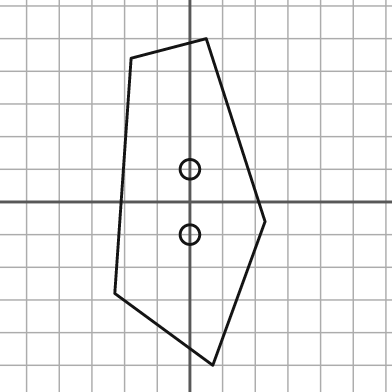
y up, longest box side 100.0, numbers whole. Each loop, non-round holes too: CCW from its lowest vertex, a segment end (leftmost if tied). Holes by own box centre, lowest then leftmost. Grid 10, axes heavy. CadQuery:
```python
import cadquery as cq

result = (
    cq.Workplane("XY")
    .moveTo(7.0, -50.0)
    .lineTo(23.0, -6.0)
    .lineTo(5.0, 50.0)
    .lineTo(-18.0, 44.0)
    .lineTo(-23.0, -28.0)
    .close()
    .moveTo(0.0, -10.0)
    .circle(3.0)
    .moveTo(0.0, 10.0)
    .circle(3.0)
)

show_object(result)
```